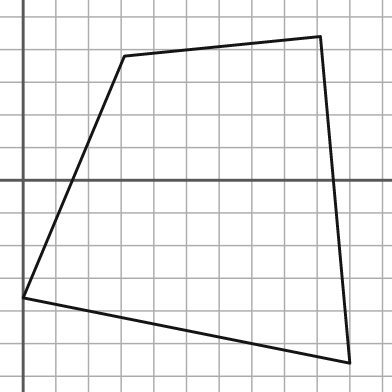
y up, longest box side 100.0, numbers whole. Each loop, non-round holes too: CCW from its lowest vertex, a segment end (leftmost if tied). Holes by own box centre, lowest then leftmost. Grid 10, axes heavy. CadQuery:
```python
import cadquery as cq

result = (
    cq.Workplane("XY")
    .moveTo(100.0, -56.0)
    .lineTo(91.0, 44.0)
    .lineTo(31.0, 38.0)
    .lineTo(0.0, -36.0)
    .close()
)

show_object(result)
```